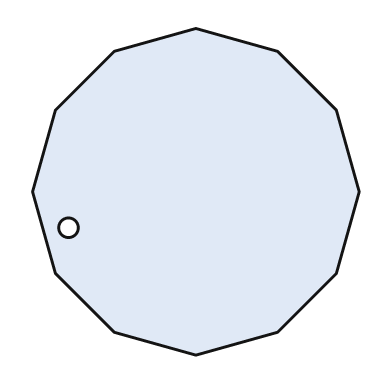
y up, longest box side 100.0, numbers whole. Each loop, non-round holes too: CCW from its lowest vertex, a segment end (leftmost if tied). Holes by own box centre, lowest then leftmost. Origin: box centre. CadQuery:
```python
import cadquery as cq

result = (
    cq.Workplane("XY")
    .moveTo(0.0, -50.0)
    .lineTo(25.0, -43.0)
    .lineTo(43.0, -25.0)
    .lineTo(50.0, 0.0)
    .lineTo(43.0, 25.0)
    .lineTo(25.0, 43.0)
    .lineTo(0.0, 50.0)
    .lineTo(-25.0, 43.0)
    .lineTo(-43.0, 25.0)
    .lineTo(-50.0, 0.0)
    .lineTo(-43.0, -25.0)
    .lineTo(-25.0, -43.0)
    .close()
    .moveTo(-39.0, -11.0)
    .circle(3.0)
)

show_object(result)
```